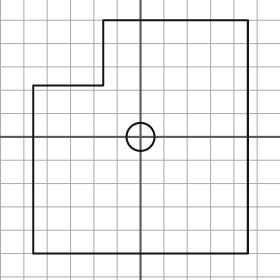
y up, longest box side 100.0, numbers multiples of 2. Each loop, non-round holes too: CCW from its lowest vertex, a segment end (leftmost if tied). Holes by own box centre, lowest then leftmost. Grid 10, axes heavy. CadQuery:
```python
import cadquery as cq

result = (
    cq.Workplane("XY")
    .moveTo(-46.0, -50.0)
    .lineTo(46.0, -50.0)
    .lineTo(46.0, 50.0)
    .lineTo(-16.0, 50.0)
    .lineTo(-16.0, 22.0)
    .lineTo(-46.0, 22.0)
    .close()
    .moveTo(0.0, 0.0)
    .circle(6.0)
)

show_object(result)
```